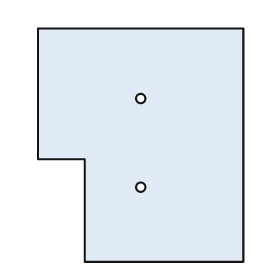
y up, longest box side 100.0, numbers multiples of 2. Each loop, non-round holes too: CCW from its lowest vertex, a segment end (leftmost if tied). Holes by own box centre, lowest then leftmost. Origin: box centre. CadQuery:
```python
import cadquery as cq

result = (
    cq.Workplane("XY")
    .moveTo(-24.0, -50.0)
    .lineTo(44.0, -50.0)
    .lineTo(44.0, 50.0)
    .lineTo(-44.0, 50.0)
    .lineTo(-44.0, -6.0)
    .lineTo(-24.0, -6.0)
    .close()
    .moveTo(0.0, -18.0)
    .circle(2.0)
    .moveTo(0.0, 20.0)
    .circle(2.0)
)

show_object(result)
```